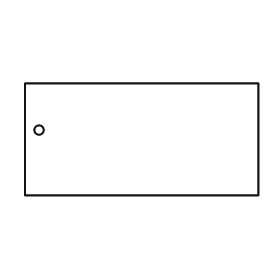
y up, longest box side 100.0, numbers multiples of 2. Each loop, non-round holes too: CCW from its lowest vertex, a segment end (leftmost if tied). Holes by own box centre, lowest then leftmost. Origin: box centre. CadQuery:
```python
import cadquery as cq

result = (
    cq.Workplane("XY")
    .moveTo(-50.0, -24.0)
    .lineTo(50.0, -24.0)
    .lineTo(50.0, 24.0)
    .lineTo(-50.0, 24.0)
    .close()
    .moveTo(-44.0, 4.0)
    .circle(2.0)
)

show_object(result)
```